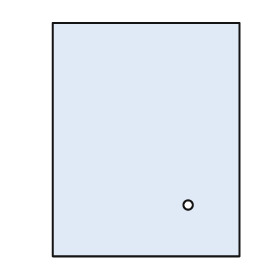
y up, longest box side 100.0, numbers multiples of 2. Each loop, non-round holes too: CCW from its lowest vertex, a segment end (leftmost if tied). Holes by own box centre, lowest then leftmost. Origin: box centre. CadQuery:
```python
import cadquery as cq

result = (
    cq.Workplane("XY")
    .moveTo(-40.0, -50.0)
    .lineTo(40.0, -50.0)
    .lineTo(40.0, 50.0)
    .lineTo(-40.0, 50.0)
    .close()
    .moveTo(18.0, -28.0)
    .circle(2.0)
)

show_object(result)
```